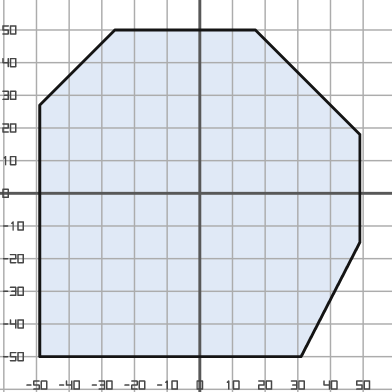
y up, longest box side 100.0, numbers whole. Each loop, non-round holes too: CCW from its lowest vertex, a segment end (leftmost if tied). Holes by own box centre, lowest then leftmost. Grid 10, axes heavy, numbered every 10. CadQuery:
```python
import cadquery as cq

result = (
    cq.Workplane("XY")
    .moveTo(-49.0, -50.0)
    .lineTo(31.0, -50.0)
    .lineTo(49.0, -15.0)
    .lineTo(49.0, 18.0)
    .lineTo(17.0, 50.0)
    .lineTo(-26.0, 50.0)
    .lineTo(-49.0, 27.0)
    .close()
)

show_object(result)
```